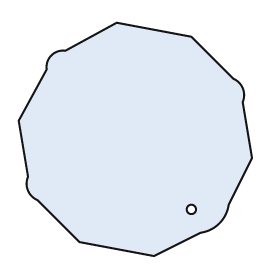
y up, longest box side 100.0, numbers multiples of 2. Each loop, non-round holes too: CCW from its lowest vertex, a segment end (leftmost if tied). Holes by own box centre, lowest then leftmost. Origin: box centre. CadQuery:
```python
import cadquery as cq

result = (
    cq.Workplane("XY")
    .moveTo(8.0, -50.0)
    .lineTo(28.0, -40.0)
    .threePointArc((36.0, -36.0), (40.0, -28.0))
    .lineTo(50.0, -8.0)
    .lineTo(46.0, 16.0)
    .threePointArc((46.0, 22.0), (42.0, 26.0))
    .lineTo(24.0, 44.0)
    .lineTo(-8.0, 50.0)
    .lineTo(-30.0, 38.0)
    .threePointArc((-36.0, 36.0), (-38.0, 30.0))
    .lineTo(-50.0, 8.0)
    .lineTo(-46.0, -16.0)
    .threePointArc((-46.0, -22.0), (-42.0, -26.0))
    .lineTo(-24.0, -44.0)
    .close()
    .moveTo(24.0, -30.0)
    .circle(2.0)
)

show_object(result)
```